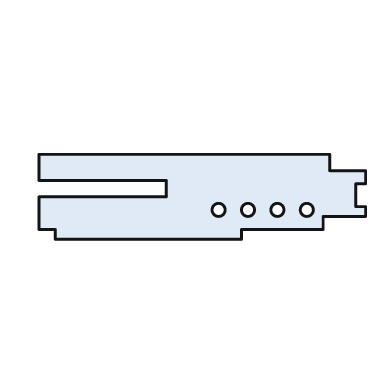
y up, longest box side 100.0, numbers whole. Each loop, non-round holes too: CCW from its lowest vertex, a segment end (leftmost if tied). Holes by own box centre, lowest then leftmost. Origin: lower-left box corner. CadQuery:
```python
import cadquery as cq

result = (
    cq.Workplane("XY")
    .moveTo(5.0, 0.0)
    .lineTo(62.0, 0.0)
    .lineTo(62.0, 3.0)
    .lineTo(87.0, 3.0)
    .lineTo(87.0, 7.0)
    .lineTo(100.0, 7.0)
    .lineTo(100.0, 10.0)
    .lineTo(97.0, 10.0)
    .lineTo(97.0, 17.0)
    .lineTo(100.0, 17.0)
    .lineTo(100.0, 21.0)
    .lineTo(89.0, 21.0)
    .lineTo(89.0, 26.0)
    .lineTo(0.0, 26.0)
    .lineTo(0.0, 18.0)
    .lineTo(39.0, 18.0)
    .lineTo(39.0, 13.0)
    .lineTo(0.0, 13.0)
    .lineTo(0.0, 3.0)
    .lineTo(5.0, 3.0)
    .close()
    .moveTo(55.0, 9.0)
    .circle(2.0)
    .moveTo(64.0, 9.0)
    .circle(2.0)
    .moveTo(73.0, 9.0)
    .circle(2.0)
    .moveTo(82.0, 9.0)
    .circle(2.0)
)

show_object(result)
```